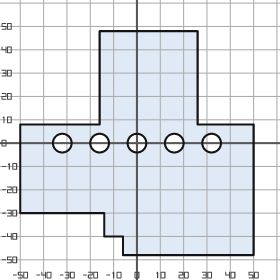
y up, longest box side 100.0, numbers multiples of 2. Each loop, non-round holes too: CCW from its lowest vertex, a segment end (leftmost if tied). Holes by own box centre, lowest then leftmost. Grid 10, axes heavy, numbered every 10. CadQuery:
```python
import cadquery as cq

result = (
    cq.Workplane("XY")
    .moveTo(-6.0, -48.0)
    .lineTo(50.0, -48.0)
    .lineTo(50.0, 8.0)
    .lineTo(26.0, 8.0)
    .lineTo(26.0, 48.0)
    .lineTo(-16.0, 48.0)
    .lineTo(-16.0, 8.0)
    .lineTo(-50.0, 8.0)
    .lineTo(-50.0, -30.0)
    .lineTo(-14.0, -30.0)
    .lineTo(-14.0, -40.0)
    .lineTo(-6.0, -40.0)
    .close()
    .moveTo(-32.0, 0.0)
    .circle(4.0)
    .moveTo(-16.0, 0.0)
    .circle(4.0)
    .moveTo(0.0, 0.0)
    .circle(4.0)
    .moveTo(16.0, 0.0)
    .circle(4.0)
    .moveTo(32.0, 0.0)
    .circle(4.0)
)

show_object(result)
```